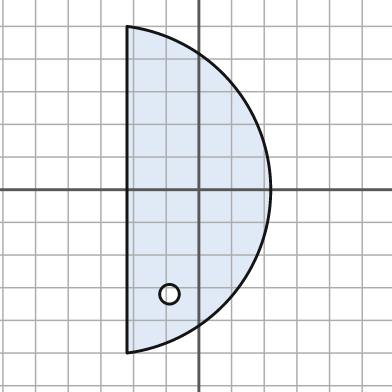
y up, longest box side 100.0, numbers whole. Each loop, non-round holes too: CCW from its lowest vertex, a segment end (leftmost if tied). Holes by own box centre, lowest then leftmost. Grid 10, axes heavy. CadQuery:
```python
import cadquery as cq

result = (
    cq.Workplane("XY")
    .moveTo(-22.0, -50.0)
    .threePointArc((22.0, 0.0), (-22.0, 50.0))
    .close()
    .moveTo(-9.0, -32.0)
    .circle(3.0)
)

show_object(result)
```